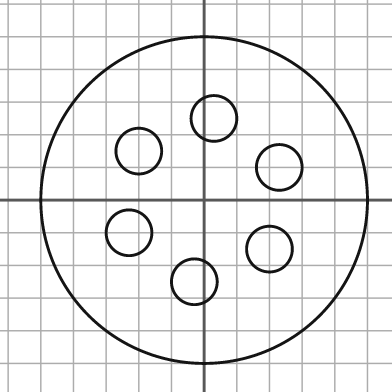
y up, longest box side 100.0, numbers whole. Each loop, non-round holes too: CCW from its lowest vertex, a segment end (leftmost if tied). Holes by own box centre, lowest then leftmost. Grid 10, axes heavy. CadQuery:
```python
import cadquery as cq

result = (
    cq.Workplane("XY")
    .moveTo(0.0, 0.0)
    .circle(50.0)
    .moveTo(-3.0, -25.0)
    .circle(7.0)
    .moveTo(20.0, -15.0)
    .circle(7.0)
    .moveTo(-23.0, -10.0)
    .circle(7.0)
    .moveTo(23.0, 10.0)
    .circle(7.0)
    .moveTo(-20.0, 15.0)
    .circle(7.0)
    .moveTo(3.0, 25.0)
    .circle(7.0)
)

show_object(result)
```